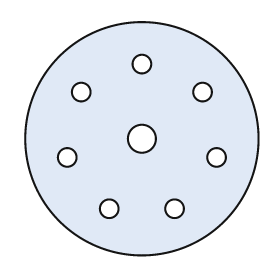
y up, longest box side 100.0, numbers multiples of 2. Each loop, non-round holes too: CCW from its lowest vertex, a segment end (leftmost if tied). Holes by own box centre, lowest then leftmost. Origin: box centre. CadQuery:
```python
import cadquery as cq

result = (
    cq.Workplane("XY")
    .moveTo(0.0, 0.0)
    .circle(50.0)
    .moveTo(-14.0, -30.0)
    .circle(4.0)
    .moveTo(14.0, -30.0)
    .circle(4.0)
    .moveTo(-32.0, -8.0)
    .circle(4.0)
    .moveTo(32.0, -8.0)
    .circle(4.0)
    .moveTo(0.0, 0.0)
    .circle(6.0)
    .moveTo(-26.0, 20.0)
    .circle(4.0)
    .moveTo(26.0, 20.0)
    .circle(4.0)
    .moveTo(0.0, 32.0)
    .circle(4.0)
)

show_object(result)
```